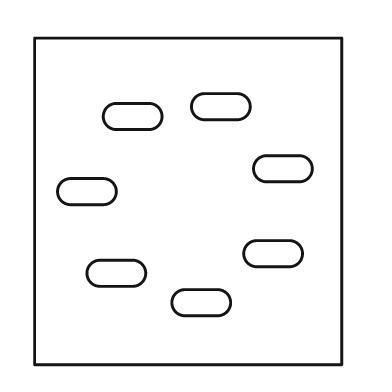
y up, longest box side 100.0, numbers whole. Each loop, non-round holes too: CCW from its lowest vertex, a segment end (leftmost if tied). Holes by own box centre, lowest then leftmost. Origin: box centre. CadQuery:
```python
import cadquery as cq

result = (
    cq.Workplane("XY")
    .moveTo(-47.0, -50.0)
    .lineTo(47.0, -50.0)
    .lineTo(47.0, 50.0)
    .lineTo(-47.0, 50.0)
    .close()
    .moveTo(-1.0, -35.0)
    .lineTo(9.0, -35.0)
    .threePointArc((13.0, -31.0), (9.0, -27.0))
    .lineTo(-1.0, -27.0)
    .threePointArc((-5.0, -31.0), (-1.0, -35.0))
    .close()
    .moveTo(-27.0, -26.0)
    .lineTo(-17.0, -26.0)
    .threePointArc((-13.0, -22.0), (-17.0, -18.0))
    .lineTo(-27.0, -18.0)
    .threePointArc((-31.0, -22.0), (-27.0, -26.0))
    .close()
    .moveTo(21.0, -20.0)
    .lineTo(31.0, -20.0)
    .threePointArc((35.0, -16.0), (31.0, -12.0))
    .lineTo(21.0, -12.0)
    .threePointArc((17.0, -16.0), (21.0, -20.0))
    .close()
    .moveTo(-36.0, -1.0)
    .lineTo(-26.0, -1.0)
    .threePointArc((-22.0, 3.0), (-26.0, 7.0))
    .lineTo(-36.0, 7.0)
    .threePointArc((-40.0, 3.0), (-36.0, -1.0))
    .close()
    .moveTo(24.0, 6.0)
    .lineTo(34.0, 6.0)
    .threePointArc((38.0, 10.0), (34.0, 14.0))
    .lineTo(24.0, 14.0)
    .threePointArc((20.0, 10.0), (24.0, 6.0))
    .close()
    .moveTo(-22.0, 22.0)
    .lineTo(-12.0, 22.0)
    .threePointArc((-8.0, 26.0), (-12.0, 30.0))
    .lineTo(-22.0, 30.0)
    .threePointArc((-26.0, 26.0), (-22.0, 22.0))
    .close()
    .moveTo(5.0, 25.0)
    .lineTo(15.0, 25.0)
    .threePointArc((19.0, 29.0), (15.0, 33.0))
    .lineTo(5.0, 33.0)
    .threePointArc((1.0, 29.0), (5.0, 25.0))
    .close()
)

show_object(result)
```